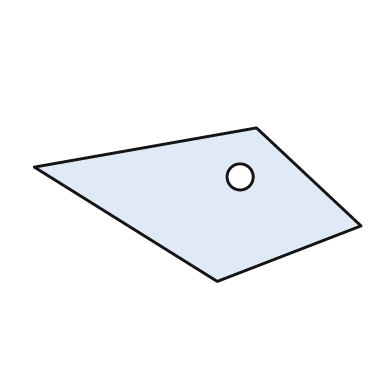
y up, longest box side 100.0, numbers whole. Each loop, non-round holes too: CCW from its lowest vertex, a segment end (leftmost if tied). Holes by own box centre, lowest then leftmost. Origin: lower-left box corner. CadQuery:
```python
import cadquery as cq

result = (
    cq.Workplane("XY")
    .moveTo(56.0, 0.0)
    .lineTo(100.0, 17.0)
    .lineTo(68.0, 47.0)
    .lineTo(0.0, 35.0)
    .close()
    .moveTo(63.0, 32.0)
    .circle(4.0)
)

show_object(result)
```